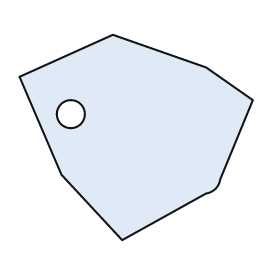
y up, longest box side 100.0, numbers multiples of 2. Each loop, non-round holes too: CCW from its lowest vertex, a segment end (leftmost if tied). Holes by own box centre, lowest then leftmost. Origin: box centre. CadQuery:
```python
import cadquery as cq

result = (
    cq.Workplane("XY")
    .moveTo(-6.0, -44.0)
    .lineTo(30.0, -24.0)
    .threePointArc((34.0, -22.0), (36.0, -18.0))
    .lineTo(50.0, 16.0)
    .lineTo(30.0, 30.0)
    .lineTo(-10.0, 44.0)
    .lineTo(-50.0, 26.0)
    .lineTo(-32.0, -16.0)
    .close()
    .moveTo(-28.0, 10.0)
    .circle(6.0)
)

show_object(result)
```